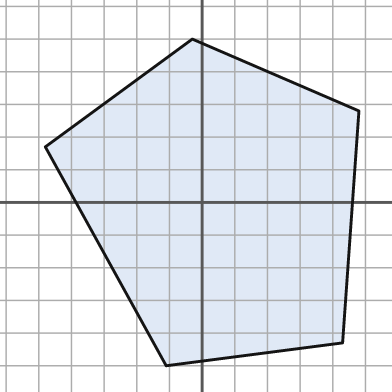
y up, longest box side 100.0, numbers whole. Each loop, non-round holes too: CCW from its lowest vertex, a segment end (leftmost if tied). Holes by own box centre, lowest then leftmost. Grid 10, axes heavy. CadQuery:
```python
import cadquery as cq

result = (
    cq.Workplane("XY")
    .moveTo(-11.0, -50.0)
    .lineTo(43.0, -43.0)
    .lineTo(48.0, 28.0)
    .lineTo(-3.0, 50.0)
    .lineTo(-48.0, 17.0)
    .close()
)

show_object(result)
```